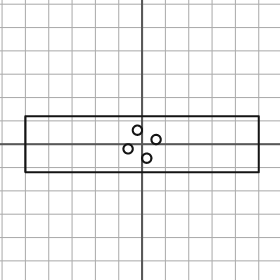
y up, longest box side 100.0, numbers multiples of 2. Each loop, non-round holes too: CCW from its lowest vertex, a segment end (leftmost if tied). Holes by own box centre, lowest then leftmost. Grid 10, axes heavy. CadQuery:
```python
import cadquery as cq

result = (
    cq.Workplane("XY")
    .moveTo(-50.0, -12.0)
    .lineTo(50.0, -12.0)
    .lineTo(50.0, 12.0)
    .lineTo(-50.0, 12.0)
    .close()
    .moveTo(2.0, -6.0)
    .circle(2.0)
    .moveTo(-6.0, -2.0)
    .circle(2.0)
    .moveTo(6.0, 2.0)
    .circle(2.0)
    .moveTo(-2.0, 6.0)
    .circle(2.0)
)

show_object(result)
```